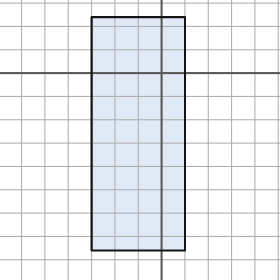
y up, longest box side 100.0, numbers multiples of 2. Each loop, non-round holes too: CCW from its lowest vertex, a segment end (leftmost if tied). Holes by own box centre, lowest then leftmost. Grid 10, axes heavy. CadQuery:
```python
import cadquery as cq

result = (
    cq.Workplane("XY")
    .moveTo(-30.0, -76.0)
    .lineTo(10.0, -76.0)
    .lineTo(10.0, 24.0)
    .lineTo(-30.0, 24.0)
    .close()
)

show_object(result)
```